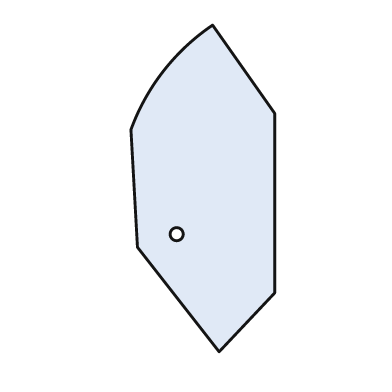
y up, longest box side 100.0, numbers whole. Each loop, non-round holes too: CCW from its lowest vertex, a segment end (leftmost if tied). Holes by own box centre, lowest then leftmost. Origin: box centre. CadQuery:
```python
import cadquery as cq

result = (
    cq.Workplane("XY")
    .moveTo(5.0, -50.0)
    .lineTo(22.0, -32.0)
    .lineTo(22.0, 23.0)
    .lineTo(3.0, 50.0)
    .threePointArc((-12.0, 36.0), (-22.0, 18.0))
    .lineTo(-20.0, -18.0)
    .close()
    .moveTo(-8.0, -14.0)
    .circle(2.0)
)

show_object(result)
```